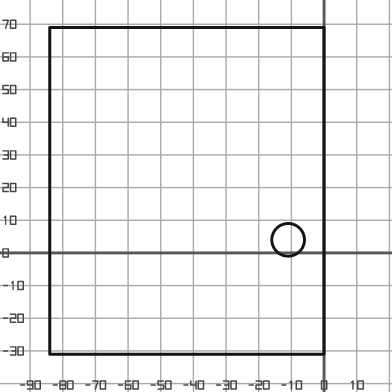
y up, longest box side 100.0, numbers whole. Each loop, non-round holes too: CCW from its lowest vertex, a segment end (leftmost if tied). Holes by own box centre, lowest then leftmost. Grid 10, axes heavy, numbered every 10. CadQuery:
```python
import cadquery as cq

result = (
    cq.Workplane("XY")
    .moveTo(-84.0, -31.0)
    .lineTo(0.0, -31.0)
    .lineTo(0.0, 69.0)
    .lineTo(-84.0, 69.0)
    .close()
    .moveTo(-11.0, 4.0)
    .circle(5.0)
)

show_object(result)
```